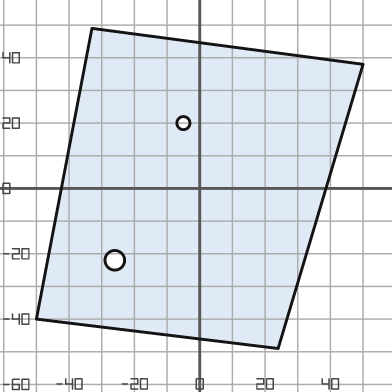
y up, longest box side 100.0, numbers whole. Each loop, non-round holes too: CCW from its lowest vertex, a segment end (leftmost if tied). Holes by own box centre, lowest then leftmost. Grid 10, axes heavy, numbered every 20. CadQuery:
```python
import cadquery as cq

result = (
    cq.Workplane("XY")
    .moveTo(24.0, -49.0)
    .lineTo(50.0, 38.0)
    .lineTo(-33.0, 49.0)
    .lineTo(-50.0, -40.0)
    .close()
    .moveTo(-26.0, -22.0)
    .circle(3.0)
    .moveTo(-5.0, 20.0)
    .circle(2.0)
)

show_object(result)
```